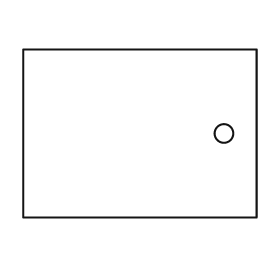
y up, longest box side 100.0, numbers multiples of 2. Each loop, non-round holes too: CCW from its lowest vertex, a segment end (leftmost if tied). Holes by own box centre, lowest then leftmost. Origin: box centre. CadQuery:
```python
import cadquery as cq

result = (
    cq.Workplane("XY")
    .moveTo(-50.0, -36.0)
    .lineTo(50.0, -36.0)
    .lineTo(50.0, 36.0)
    .lineTo(-50.0, 36.0)
    .close()
    .moveTo(36.0, 0.0)
    .circle(4.0)
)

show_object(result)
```